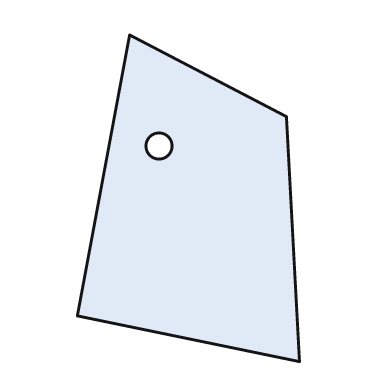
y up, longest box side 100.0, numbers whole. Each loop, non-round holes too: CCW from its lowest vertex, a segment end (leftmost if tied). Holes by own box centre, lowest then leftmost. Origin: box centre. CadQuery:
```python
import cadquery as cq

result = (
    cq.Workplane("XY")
    .moveTo(34.0, -50.0)
    .lineTo(30.0, 25.0)
    .lineTo(-18.0, 50.0)
    .lineTo(-34.0, -36.0)
    .close()
    .moveTo(-9.0, 16.0)
    .circle(4.0)
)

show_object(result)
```